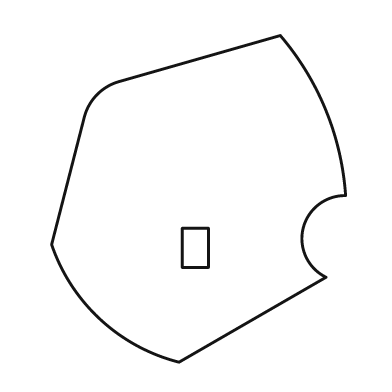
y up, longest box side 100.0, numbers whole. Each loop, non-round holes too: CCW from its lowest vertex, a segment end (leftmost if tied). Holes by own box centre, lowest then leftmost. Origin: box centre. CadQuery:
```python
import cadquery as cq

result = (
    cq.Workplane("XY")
    .moveTo(-6.0, -50.0)
    .lineTo(39.0, -24.0)
    .threePointArc((32.0, -9.0), (45.0, 1.0))
    .threePointArc((39.0, 27.0), (25.0, 50.0))
    .lineTo(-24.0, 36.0)
    .threePointArc((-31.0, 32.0), (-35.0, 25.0))
    .lineTo(-45.0, -14.0)
    .threePointArc((-30.0, -37.0), (-6.0, -50.0))
    .close()
    .moveTo(-5.0, -21.0)
    .lineTo(3.0, -21.0)
    .lineTo(3.0, -9.0)
    .lineTo(-5.0, -9.0)
    .close()
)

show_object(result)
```